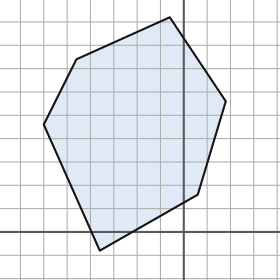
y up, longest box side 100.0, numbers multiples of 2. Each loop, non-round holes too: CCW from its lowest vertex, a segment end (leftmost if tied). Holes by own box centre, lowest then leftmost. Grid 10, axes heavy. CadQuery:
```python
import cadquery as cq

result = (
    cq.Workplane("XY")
    .moveTo(-36.0, -8.0)
    .lineTo(6.0, 16.0)
    .lineTo(18.0, 56.0)
    .lineTo(-6.0, 92.0)
    .lineTo(-46.0, 74.0)
    .lineTo(-60.0, 46.0)
    .close()
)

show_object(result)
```